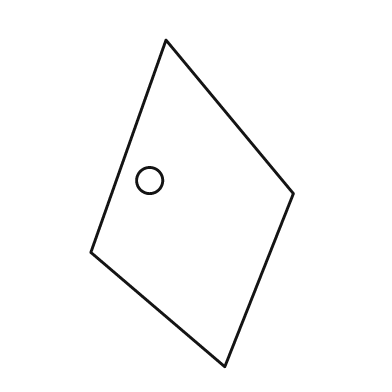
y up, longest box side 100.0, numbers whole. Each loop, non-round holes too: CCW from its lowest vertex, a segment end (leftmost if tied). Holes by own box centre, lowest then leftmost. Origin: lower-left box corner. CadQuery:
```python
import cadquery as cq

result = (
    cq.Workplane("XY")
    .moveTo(41.0, 0.0)
    .lineTo(62.0, 53.0)
    .lineTo(23.0, 100.0)
    .lineTo(0.0, 35.0)
    .close()
    .moveTo(18.0, 57.0)
    .circle(4.0)
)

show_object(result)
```